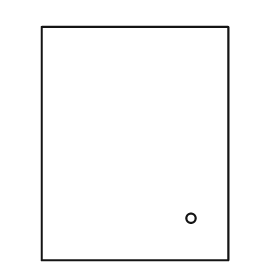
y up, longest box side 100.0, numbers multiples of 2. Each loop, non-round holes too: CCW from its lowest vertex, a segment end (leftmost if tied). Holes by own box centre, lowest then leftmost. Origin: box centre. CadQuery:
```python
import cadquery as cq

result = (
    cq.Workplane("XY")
    .moveTo(-40.0, -50.0)
    .lineTo(40.0, -50.0)
    .lineTo(40.0, 50.0)
    .lineTo(-40.0, 50.0)
    .close()
    .moveTo(24.0, -32.0)
    .circle(2.0)
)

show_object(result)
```